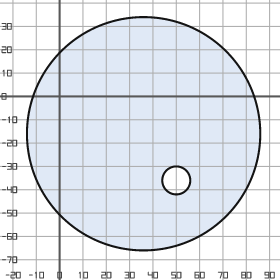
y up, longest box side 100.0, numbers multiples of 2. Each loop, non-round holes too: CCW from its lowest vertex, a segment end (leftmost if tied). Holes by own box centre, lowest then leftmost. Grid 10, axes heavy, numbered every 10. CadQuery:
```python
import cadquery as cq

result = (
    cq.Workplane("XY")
    .moveTo(36.0, -16.0)
    .circle(50.0)
    .moveTo(50.0, -36.0)
    .circle(6.0)
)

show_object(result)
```